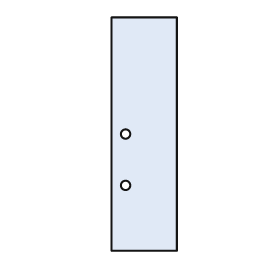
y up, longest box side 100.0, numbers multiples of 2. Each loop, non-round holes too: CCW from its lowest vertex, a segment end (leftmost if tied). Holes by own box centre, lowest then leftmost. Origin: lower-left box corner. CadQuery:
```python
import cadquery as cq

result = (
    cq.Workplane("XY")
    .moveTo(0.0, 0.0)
    .lineTo(28.0, 0.0)
    .lineTo(28.0, 100.0)
    .lineTo(0.0, 100.0)
    .close()
    .moveTo(6.0, 28.0)
    .circle(2.0)
    .moveTo(6.0, 50.0)
    .circle(2.0)
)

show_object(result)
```